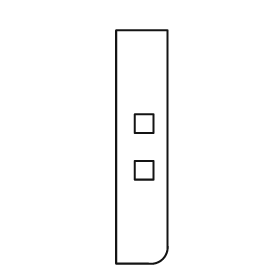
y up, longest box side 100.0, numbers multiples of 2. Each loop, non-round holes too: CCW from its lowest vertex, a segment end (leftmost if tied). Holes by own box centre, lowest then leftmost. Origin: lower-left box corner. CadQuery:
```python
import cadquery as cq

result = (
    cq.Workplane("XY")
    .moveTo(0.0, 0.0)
    .lineTo(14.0, 0.0)
    .threePointArc((20.0, 2.0), (22.0, 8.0))
    .lineTo(22.0, 100.0)
    .lineTo(0.0, 100.0)
    .close()
    .moveTo(8.0, 36.0)
    .lineTo(16.0, 36.0)
    .lineTo(16.0, 44.0)
    .lineTo(8.0, 44.0)
    .close()
    .moveTo(8.0, 56.0)
    .lineTo(16.0, 56.0)
    .lineTo(16.0, 64.0)
    .lineTo(8.0, 64.0)
    .close()
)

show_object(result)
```